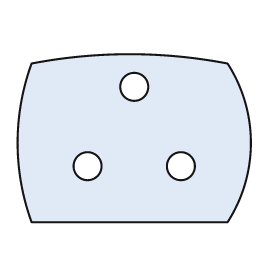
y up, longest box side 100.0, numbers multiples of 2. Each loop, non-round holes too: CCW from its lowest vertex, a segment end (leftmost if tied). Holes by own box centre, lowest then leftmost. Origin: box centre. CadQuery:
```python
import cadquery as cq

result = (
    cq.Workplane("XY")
    .moveTo(-44.0, -36.0)
    .lineTo(40.0, -36.0)
    .threePointArc((50.0, -2.0), (40.0, 32.0))
    .threePointArc((-2.0, 36.0), (-44.0, 32.0))
    .threePointArc((-50.0, -2.0), (-44.0, -36.0))
    .close()
    .moveTo(-20.0, -12.0)
    .circle(6.0)
    .moveTo(20.0, -12.0)
    .circle(6.0)
    .moveTo(0.0, 22.0)
    .circle(6.0)
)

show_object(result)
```